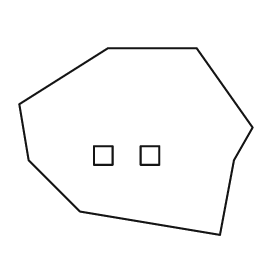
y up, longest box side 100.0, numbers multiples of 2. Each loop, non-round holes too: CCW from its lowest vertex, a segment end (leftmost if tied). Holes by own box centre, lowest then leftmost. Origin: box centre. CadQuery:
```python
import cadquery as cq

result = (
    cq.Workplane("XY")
    .moveTo(36.0, -40.0)
    .lineTo(42.0, -8.0)
    .lineTo(50.0, 6.0)
    .lineTo(26.0, 40.0)
    .lineTo(-12.0, 40.0)
    .lineTo(-50.0, 16.0)
    .lineTo(-46.0, -8.0)
    .lineTo(-24.0, -30.0)
    .close()
    .moveTo(-18.0, -10.0)
    .lineTo(-10.0, -10.0)
    .lineTo(-10.0, -2.0)
    .lineTo(-18.0, -2.0)
    .close()
    .moveTo(2.0, -10.0)
    .lineTo(10.0, -10.0)
    .lineTo(10.0, -2.0)
    .lineTo(2.0, -2.0)
    .close()
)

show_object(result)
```